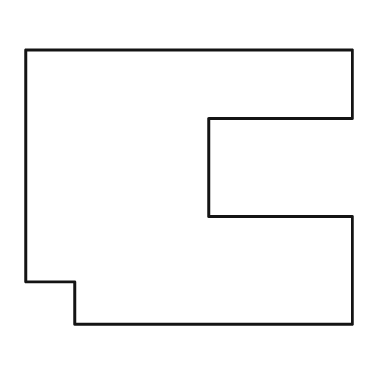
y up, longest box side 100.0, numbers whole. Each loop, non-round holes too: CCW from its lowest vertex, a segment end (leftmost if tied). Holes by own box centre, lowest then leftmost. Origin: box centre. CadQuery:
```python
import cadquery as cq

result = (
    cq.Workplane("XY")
    .moveTo(-35.0, -42.0)
    .lineTo(50.0, -42.0)
    .lineTo(50.0, -9.0)
    .lineTo(6.0, -9.0)
    .lineTo(6.0, 21.0)
    .lineTo(50.0, 21.0)
    .lineTo(50.0, 42.0)
    .lineTo(-50.0, 42.0)
    .lineTo(-50.0, -29.0)
    .lineTo(-35.0, -29.0)
    .close()
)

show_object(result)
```